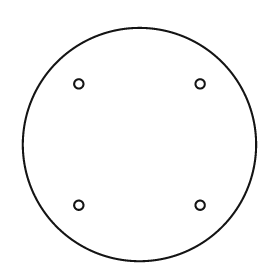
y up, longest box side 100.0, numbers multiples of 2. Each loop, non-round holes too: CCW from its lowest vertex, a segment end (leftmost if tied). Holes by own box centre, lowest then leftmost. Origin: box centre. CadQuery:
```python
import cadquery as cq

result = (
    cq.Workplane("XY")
    .moveTo(0.0, 0.0)
    .circle(50.0)
    .moveTo(-26.0, -26.0)
    .circle(2.0)
    .moveTo(26.0, -26.0)
    .circle(2.0)
    .moveTo(-26.0, 26.0)
    .circle(2.0)
    .moveTo(26.0, 26.0)
    .circle(2.0)
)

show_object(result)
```